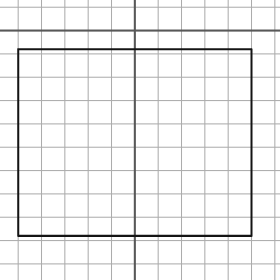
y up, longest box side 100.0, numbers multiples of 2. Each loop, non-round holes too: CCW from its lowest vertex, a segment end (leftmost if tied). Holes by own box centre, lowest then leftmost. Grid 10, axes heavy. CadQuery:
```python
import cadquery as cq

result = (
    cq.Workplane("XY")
    .moveTo(-50.0, -88.0)
    .lineTo(50.0, -88.0)
    .lineTo(50.0, -8.0)
    .lineTo(-50.0, -8.0)
    .close()
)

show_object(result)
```